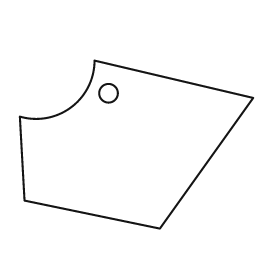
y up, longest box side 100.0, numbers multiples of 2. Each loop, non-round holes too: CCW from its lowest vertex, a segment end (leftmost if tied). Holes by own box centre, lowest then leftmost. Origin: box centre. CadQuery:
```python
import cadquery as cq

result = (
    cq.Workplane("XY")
    .moveTo(10.0, -36.0)
    .lineTo(50.0, 20.0)
    .lineTo(-18.0, 36.0)
    .threePointArc((-28.0, 16.0), (-50.0, 12.0))
    .lineTo(-48.0, -24.0)
    .close()
    .moveTo(-12.0, 22.0)
    .circle(4.0)
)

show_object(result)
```